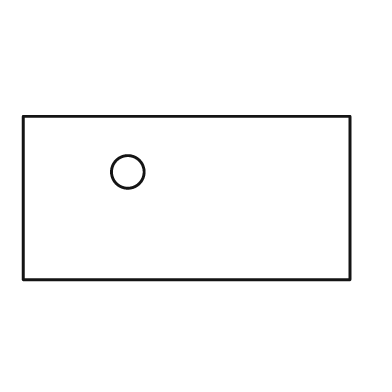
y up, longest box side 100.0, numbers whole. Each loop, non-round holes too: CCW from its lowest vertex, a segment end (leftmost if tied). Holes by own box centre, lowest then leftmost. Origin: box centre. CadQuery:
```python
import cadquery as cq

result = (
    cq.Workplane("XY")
    .moveTo(-50.0, -25.0)
    .lineTo(50.0, -25.0)
    .lineTo(50.0, 25.0)
    .lineTo(-50.0, 25.0)
    .close()
    .moveTo(-18.0, 8.0)
    .circle(5.0)
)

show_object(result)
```